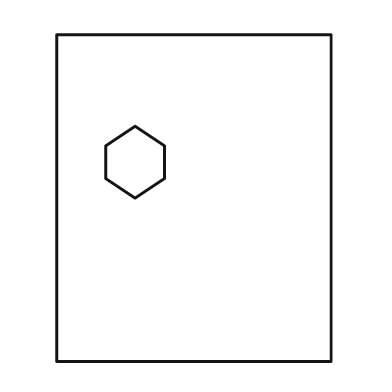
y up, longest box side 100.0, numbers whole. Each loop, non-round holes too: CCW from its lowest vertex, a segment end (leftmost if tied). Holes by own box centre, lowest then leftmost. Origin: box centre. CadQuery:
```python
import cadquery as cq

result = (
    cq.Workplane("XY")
    .moveTo(-42.0, -50.0)
    .lineTo(42.0, -50.0)
    .lineTo(42.0, 50.0)
    .lineTo(-42.0, 50.0)
    .close()
    .moveTo(-18.0, 0.0)
    .lineTo(-9.0, 6.0)
    .lineTo(-9.0, 16.0)
    .lineTo(-18.0, 22.0)
    .lineTo(-27.0, 16.0)
    .lineTo(-27.0, 6.0)
    .close()
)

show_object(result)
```